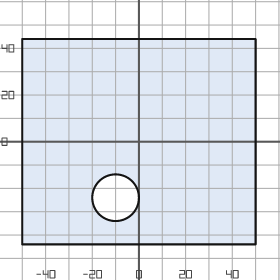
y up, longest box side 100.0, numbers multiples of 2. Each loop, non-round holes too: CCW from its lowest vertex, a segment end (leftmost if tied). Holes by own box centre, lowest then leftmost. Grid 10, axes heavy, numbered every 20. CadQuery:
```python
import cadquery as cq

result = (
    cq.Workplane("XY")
    .moveTo(-50.0, -44.0)
    .lineTo(50.0, -44.0)
    .lineTo(50.0, 44.0)
    .lineTo(-50.0, 44.0)
    .close()
    .moveTo(-10.0, -24.0)
    .circle(10.0)
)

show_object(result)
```